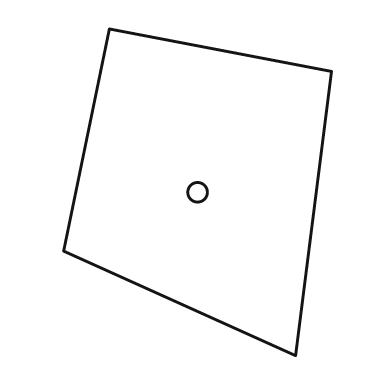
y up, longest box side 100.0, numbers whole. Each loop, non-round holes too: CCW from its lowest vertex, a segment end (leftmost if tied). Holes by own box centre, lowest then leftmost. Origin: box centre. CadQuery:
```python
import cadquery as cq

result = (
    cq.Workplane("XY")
    .moveTo(30.0, -50.0)
    .lineTo(41.0, 37.0)
    .lineTo(-27.0, 50.0)
    .lineTo(-41.0, -18.0)
    .close()
    .moveTo(0.0, 0.0)
    .circle(3.0)
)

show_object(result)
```